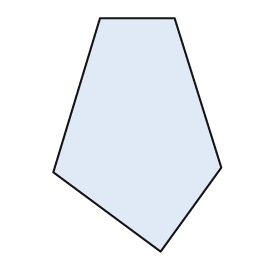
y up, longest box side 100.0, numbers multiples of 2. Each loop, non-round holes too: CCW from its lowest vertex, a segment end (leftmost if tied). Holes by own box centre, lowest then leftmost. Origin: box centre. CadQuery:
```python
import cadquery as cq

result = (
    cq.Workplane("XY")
    .moveTo(10.0, -50.0)
    .lineTo(36.0, -14.0)
    .lineTo(16.0, 50.0)
    .lineTo(-16.0, 50.0)
    .lineTo(-36.0, -16.0)
    .close()
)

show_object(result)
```